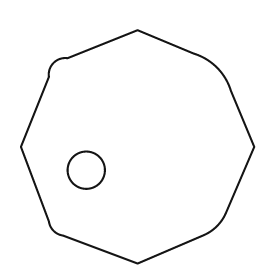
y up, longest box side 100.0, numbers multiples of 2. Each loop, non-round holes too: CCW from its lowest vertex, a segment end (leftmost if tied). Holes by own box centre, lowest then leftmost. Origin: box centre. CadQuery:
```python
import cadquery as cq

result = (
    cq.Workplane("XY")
    .moveTo(0.0, -50.0)
    .lineTo(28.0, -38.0)
    .threePointArc((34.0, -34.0), (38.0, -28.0))
    .lineTo(50.0, 0.0)
    .lineTo(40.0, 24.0)
    .threePointArc((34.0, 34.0), (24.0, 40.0))
    .lineTo(0.0, 50.0)
    .lineTo(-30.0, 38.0)
    .threePointArc((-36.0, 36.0), (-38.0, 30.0))
    .lineTo(-50.0, 0.0)
    .lineTo(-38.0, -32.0)
    .threePointArc((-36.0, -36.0), (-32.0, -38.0))
    .close()
    .moveTo(-22.0, -10.0)
    .circle(8.0)
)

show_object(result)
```